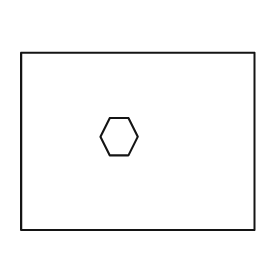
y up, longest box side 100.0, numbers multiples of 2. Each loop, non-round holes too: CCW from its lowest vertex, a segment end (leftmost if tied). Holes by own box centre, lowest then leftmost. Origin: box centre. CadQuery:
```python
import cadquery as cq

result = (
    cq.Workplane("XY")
    .moveTo(-50.0, -38.0)
    .lineTo(50.0, -38.0)
    .lineTo(50.0, 38.0)
    .lineTo(-50.0, 38.0)
    .close()
    .moveTo(-12.0, -6.0)
    .lineTo(-4.0, -6.0)
    .lineTo(0.0, 2.0)
    .lineTo(-4.0, 10.0)
    .lineTo(-12.0, 10.0)
    .lineTo(-16.0, 2.0)
    .close()
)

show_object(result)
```